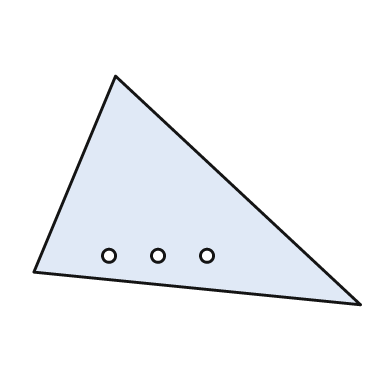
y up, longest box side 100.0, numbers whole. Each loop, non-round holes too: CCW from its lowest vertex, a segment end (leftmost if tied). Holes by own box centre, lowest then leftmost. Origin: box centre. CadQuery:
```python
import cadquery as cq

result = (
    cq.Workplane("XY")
    .moveTo(50.0, -35.0)
    .lineTo(-25.0, 35.0)
    .lineTo(-50.0, -25.0)
    .close()
    .moveTo(-27.0, -20.0)
    .circle(2.0)
    .moveTo(-12.0, -20.0)
    .circle(2.0)
    .moveTo(3.0, -20.0)
    .circle(2.0)
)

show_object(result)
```